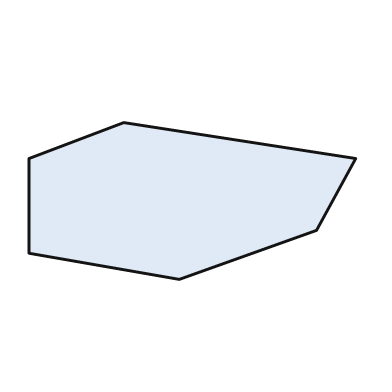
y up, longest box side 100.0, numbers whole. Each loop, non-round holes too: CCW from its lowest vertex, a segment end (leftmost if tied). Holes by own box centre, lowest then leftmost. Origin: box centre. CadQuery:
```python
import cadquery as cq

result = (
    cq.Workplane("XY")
    .moveTo(-4.0, -24.0)
    .lineTo(38.0, -9.0)
    .lineTo(50.0, 13.0)
    .lineTo(-21.0, 24.0)
    .lineTo(-50.0, 13.0)
    .lineTo(-50.0, -16.0)
    .close()
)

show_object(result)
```